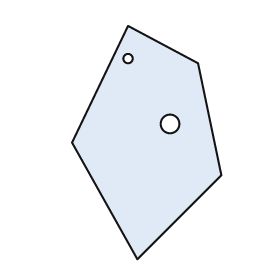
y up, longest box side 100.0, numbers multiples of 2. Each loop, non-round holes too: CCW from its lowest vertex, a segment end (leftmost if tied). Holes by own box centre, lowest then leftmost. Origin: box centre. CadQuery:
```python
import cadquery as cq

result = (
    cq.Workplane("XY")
    .moveTo(-4.0, -50.0)
    .lineTo(32.0, -14.0)
    .lineTo(22.0, 34.0)
    .lineTo(-8.0, 50.0)
    .lineTo(-32.0, 0.0)
    .close()
    .moveTo(10.0, 8.0)
    .circle(4.0)
    .moveTo(-8.0, 36.0)
    .circle(2.0)
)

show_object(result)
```